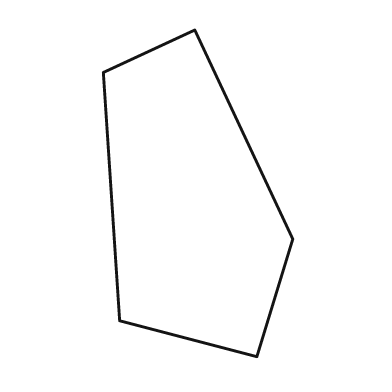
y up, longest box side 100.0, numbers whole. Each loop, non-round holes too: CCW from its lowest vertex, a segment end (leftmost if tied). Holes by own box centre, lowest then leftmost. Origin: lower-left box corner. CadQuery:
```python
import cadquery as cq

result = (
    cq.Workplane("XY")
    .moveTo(47.0, 0.0)
    .lineTo(58.0, 36.0)
    .lineTo(28.0, 100.0)
    .lineTo(0.0, 87.0)
    .lineTo(5.0, 11.0)
    .close()
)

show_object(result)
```